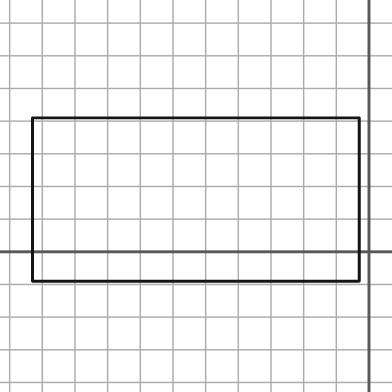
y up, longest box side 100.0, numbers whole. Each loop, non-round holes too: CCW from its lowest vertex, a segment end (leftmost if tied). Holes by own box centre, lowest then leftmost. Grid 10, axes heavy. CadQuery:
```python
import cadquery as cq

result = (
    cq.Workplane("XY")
    .moveTo(-103.0, -9.0)
    .lineTo(-3.0, -9.0)
    .lineTo(-3.0, 41.0)
    .lineTo(-103.0, 41.0)
    .close()
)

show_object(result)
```